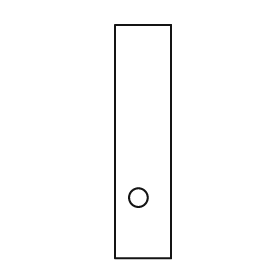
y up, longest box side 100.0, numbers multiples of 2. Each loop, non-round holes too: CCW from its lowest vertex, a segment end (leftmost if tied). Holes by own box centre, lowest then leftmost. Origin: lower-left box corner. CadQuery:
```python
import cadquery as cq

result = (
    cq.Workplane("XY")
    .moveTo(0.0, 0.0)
    .lineTo(24.0, 0.0)
    .lineTo(24.0, 100.0)
    .lineTo(0.0, 100.0)
    .close()
    .moveTo(10.0, 26.0)
    .circle(4.0)
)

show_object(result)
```